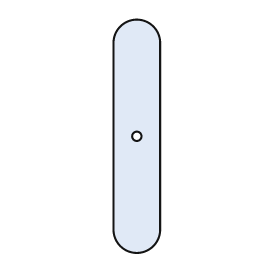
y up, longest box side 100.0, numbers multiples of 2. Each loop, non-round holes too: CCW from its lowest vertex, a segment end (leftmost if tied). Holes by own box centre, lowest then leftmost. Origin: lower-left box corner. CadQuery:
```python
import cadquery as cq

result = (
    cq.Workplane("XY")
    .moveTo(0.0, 10.0)
    .threePointArc((10.0, 0.0), (20.0, 10.0))
    .lineTo(20.0, 90.0)
    .threePointArc((10.0, 100.0), (0.0, 90.0))
    .close()
    .moveTo(10.0, 50.0)
    .circle(2.0)
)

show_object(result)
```